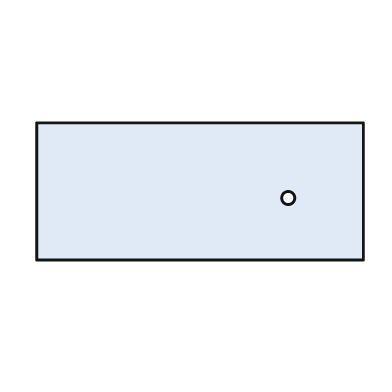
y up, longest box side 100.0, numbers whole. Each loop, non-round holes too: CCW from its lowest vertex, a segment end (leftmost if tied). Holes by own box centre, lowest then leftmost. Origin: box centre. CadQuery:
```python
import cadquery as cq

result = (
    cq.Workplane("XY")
    .moveTo(-50.0, -21.0)
    .lineTo(50.0, -21.0)
    .lineTo(50.0, 21.0)
    .lineTo(-50.0, 21.0)
    .close()
    .moveTo(27.0, -2.0)
    .circle(2.0)
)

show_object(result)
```